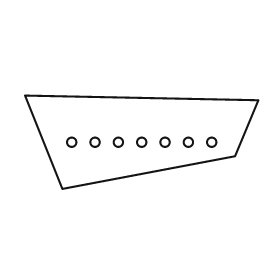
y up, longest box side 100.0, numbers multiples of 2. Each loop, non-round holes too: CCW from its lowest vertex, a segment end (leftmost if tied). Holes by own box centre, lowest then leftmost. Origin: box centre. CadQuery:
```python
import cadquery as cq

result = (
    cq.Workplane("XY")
    .moveTo(-34.0, -20.0)
    .lineTo(40.0, -6.0)
    .lineTo(50.0, 18.0)
    .lineTo(-50.0, 20.0)
    .close()
    .moveTo(-30.0, 0.0)
    .circle(2.0)
    .moveTo(-20.0, 0.0)
    .circle(2.0)
    .moveTo(-10.0, 0.0)
    .circle(2.0)
    .moveTo(0.0, 0.0)
    .circle(2.0)
    .moveTo(10.0, 0.0)
    .circle(2.0)
    .moveTo(20.0, 0.0)
    .circle(2.0)
    .moveTo(30.0, 0.0)
    .circle(2.0)
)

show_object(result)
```